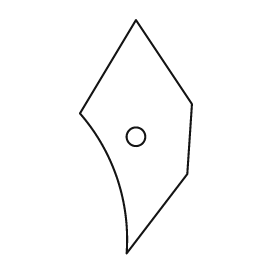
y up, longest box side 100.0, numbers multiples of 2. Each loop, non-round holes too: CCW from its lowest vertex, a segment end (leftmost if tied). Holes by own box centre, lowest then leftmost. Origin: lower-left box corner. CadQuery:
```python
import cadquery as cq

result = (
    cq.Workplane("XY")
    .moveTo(20.0, 0.0)
    .lineTo(46.0, 34.0)
    .lineTo(48.0, 64.0)
    .lineTo(24.0, 100.0)
    .lineTo(0.0, 60.0)
    .threePointArc((16.0, 32.0), (20.0, 0.0))
    .close()
    .moveTo(24.0, 50.0)
    .circle(4.0)
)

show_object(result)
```